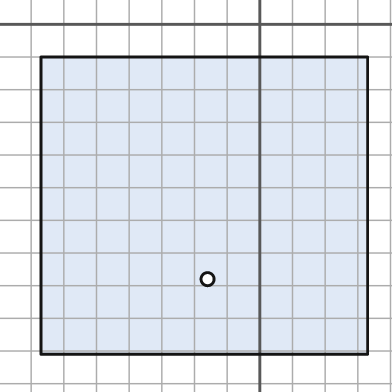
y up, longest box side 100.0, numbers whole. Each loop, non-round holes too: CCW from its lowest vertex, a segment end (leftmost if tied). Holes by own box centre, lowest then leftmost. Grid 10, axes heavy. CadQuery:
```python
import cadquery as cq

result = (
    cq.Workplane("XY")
    .moveTo(-67.0, -101.0)
    .lineTo(33.0, -101.0)
    .lineTo(33.0, -10.0)
    .lineTo(-67.0, -10.0)
    .close()
    .moveTo(-16.0, -78.0)
    .circle(2.0)
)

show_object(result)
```